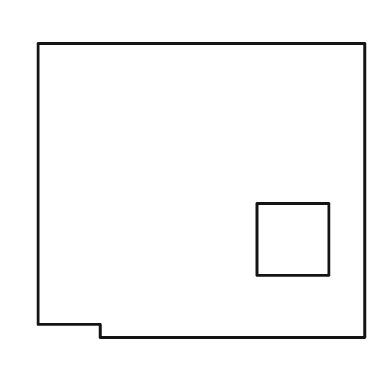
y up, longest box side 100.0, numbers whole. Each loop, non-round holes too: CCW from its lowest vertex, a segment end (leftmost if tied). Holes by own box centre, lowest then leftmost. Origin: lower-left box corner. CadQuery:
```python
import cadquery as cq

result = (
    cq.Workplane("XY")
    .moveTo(19.0, 0.0)
    .lineTo(100.0, 0.0)
    .lineTo(100.0, 90.0)
    .lineTo(0.0, 90.0)
    .lineTo(0.0, 4.0)
    .lineTo(19.0, 4.0)
    .close()
    .moveTo(67.0, 19.0)
    .lineTo(89.0, 19.0)
    .lineTo(89.0, 41.0)
    .lineTo(67.0, 41.0)
    .close()
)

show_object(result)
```